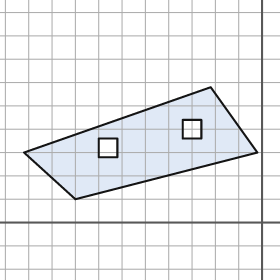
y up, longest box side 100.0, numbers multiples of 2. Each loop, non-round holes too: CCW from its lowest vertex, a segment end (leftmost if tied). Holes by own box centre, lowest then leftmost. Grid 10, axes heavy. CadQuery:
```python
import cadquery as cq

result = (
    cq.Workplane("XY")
    .moveTo(-80.0, 10.0)
    .lineTo(-2.0, 30.0)
    .lineTo(-22.0, 58.0)
    .lineTo(-102.0, 30.0)
    .close()
    .moveTo(-70.0, 28.0)
    .lineTo(-62.0, 28.0)
    .lineTo(-62.0, 36.0)
    .lineTo(-70.0, 36.0)
    .close()
    .moveTo(-34.0, 36.0)
    .lineTo(-26.0, 36.0)
    .lineTo(-26.0, 44.0)
    .lineTo(-34.0, 44.0)
    .close()
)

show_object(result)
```